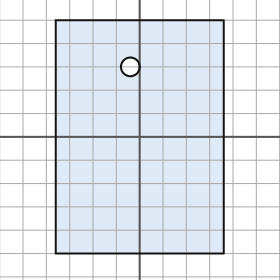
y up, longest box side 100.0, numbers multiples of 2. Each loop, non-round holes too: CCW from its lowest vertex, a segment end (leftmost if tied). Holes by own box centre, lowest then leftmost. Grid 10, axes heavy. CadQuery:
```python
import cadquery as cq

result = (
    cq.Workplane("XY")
    .moveTo(-36.0, -50.0)
    .lineTo(36.0, -50.0)
    .lineTo(36.0, 50.0)
    .lineTo(-36.0, 50.0)
    .close()
    .moveTo(-4.0, 30.0)
    .circle(4.0)
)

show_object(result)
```